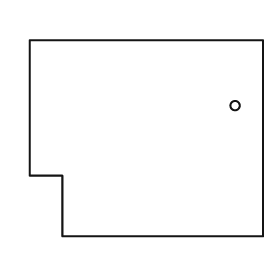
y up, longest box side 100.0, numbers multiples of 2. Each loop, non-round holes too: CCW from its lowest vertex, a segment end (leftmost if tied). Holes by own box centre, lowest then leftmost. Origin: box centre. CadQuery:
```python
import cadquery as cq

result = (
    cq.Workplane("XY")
    .moveTo(-36.0, -42.0)
    .lineTo(50.0, -42.0)
    .lineTo(50.0, 42.0)
    .lineTo(-50.0, 42.0)
    .lineTo(-50.0, -16.0)
    .lineTo(-36.0, -16.0)
    .close()
    .moveTo(38.0, 14.0)
    .circle(2.0)
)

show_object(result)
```